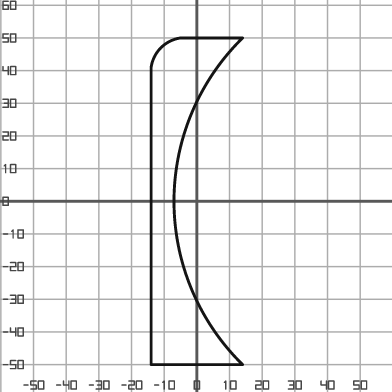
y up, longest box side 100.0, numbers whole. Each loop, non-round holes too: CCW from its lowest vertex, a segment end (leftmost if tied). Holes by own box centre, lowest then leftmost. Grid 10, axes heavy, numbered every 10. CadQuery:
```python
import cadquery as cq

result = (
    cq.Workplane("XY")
    .moveTo(-14.0, -50.0)
    .lineTo(14.0, -50.0)
    .threePointArc((-7.0, 0.0), (14.0, 50.0))
    .lineTo(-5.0, 50.0)
    .threePointArc((-11.0, 47.0), (-14.0, 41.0))
    .close()
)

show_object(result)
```